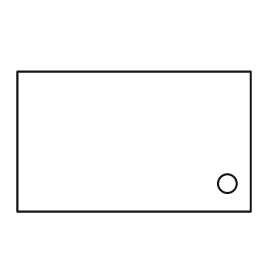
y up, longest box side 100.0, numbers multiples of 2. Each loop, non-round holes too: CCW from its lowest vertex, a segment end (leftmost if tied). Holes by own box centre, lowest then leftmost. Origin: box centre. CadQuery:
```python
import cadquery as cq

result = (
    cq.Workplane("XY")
    .moveTo(-50.0, -30.0)
    .lineTo(50.0, -30.0)
    .lineTo(50.0, 30.0)
    .lineTo(-50.0, 30.0)
    .close()
    .moveTo(40.0, -18.0)
    .circle(4.0)
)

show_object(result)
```